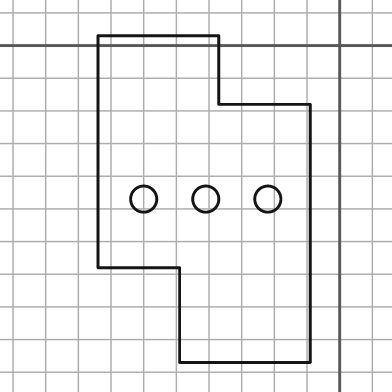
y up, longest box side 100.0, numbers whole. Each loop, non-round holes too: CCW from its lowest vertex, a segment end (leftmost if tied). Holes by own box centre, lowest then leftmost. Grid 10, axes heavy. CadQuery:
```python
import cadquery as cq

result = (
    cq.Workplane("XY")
    .moveTo(-49.0, -97.0)
    .lineTo(-9.0, -97.0)
    .lineTo(-9.0, -18.0)
    .lineTo(-37.0, -18.0)
    .lineTo(-37.0, 3.0)
    .lineTo(-74.0, 3.0)
    .lineTo(-74.0, -68.0)
    .lineTo(-49.0, -68.0)
    .close()
    .moveTo(-60.0, -47.0)
    .circle(4.0)
    .moveTo(-41.0, -47.0)
    .circle(4.0)
    .moveTo(-22.0, -47.0)
    .circle(4.0)
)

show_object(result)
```